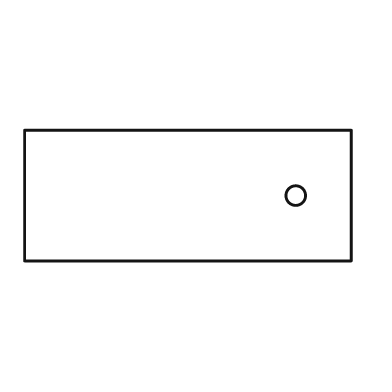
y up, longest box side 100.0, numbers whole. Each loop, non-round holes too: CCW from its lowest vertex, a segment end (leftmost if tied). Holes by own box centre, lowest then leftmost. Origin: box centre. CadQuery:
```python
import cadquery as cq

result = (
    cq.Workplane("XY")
    .moveTo(-50.0, -20.0)
    .lineTo(50.0, -20.0)
    .lineTo(50.0, 20.0)
    .lineTo(-50.0, 20.0)
    .close()
    .moveTo(33.0, 0.0)
    .circle(3.0)
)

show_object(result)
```